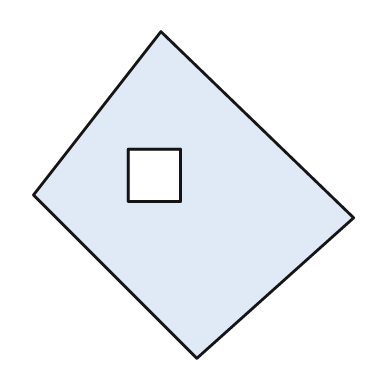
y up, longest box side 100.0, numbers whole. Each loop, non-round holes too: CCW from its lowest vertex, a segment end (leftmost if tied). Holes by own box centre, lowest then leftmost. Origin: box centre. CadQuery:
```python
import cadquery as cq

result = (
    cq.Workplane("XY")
    .moveTo(1.0, -50.0)
    .lineTo(49.0, -7.0)
    .lineTo(-10.0, 50.0)
    .lineTo(-49.0, 0.0)
    .close()
    .moveTo(-20.0, -2.0)
    .lineTo(-4.0, -2.0)
    .lineTo(-4.0, 14.0)
    .lineTo(-20.0, 14.0)
    .close()
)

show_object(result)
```